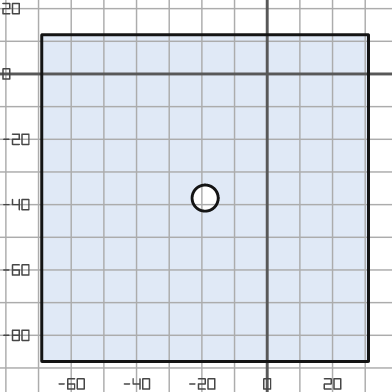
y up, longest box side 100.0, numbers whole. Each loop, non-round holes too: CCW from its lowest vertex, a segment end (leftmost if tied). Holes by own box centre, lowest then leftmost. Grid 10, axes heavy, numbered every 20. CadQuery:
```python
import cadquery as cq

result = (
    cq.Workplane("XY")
    .moveTo(-69.0, -88.0)
    .lineTo(31.0, -88.0)
    .lineTo(31.0, 12.0)
    .lineTo(-69.0, 12.0)
    .close()
    .moveTo(-19.0, -38.0)
    .circle(4.0)
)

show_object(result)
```